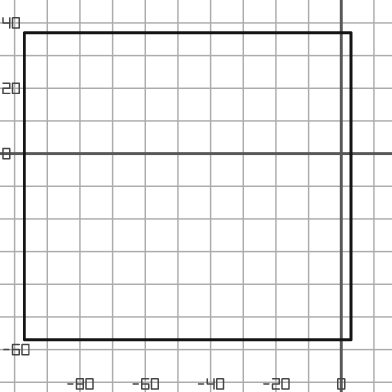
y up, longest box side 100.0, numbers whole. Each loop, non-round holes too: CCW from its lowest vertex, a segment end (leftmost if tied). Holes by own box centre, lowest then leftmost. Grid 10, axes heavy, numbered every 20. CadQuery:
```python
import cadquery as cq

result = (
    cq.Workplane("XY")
    .moveTo(-97.0, -57.0)
    .lineTo(3.0, -57.0)
    .lineTo(3.0, 37.0)
    .lineTo(-97.0, 37.0)
    .close()
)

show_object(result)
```